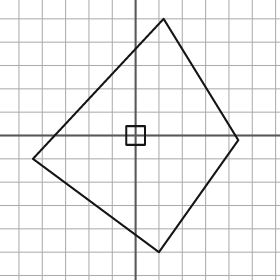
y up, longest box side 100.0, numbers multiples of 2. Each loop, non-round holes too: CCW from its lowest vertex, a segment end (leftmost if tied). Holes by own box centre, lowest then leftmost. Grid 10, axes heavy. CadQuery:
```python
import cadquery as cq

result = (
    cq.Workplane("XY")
    .moveTo(10.0, -50.0)
    .lineTo(44.0, -2.0)
    .lineTo(12.0, 50.0)
    .lineTo(-44.0, -10.0)
    .close()
    .moveTo(-4.0, -4.0)
    .lineTo(4.0, -4.0)
    .lineTo(4.0, 4.0)
    .lineTo(-4.0, 4.0)
    .close()
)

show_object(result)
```